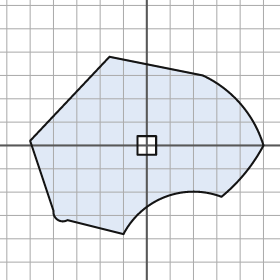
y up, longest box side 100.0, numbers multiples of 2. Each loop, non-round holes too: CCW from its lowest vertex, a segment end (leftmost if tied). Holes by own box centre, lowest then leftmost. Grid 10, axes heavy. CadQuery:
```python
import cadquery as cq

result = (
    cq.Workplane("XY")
    .moveTo(-10.0, -38.0)
    .threePointArc((8.0, -22.0), (32.0, -22.0))
    .threePointArc((42.0, -12.0), (50.0, 0.0))
    .threePointArc((40.0, 18.0), (24.0, 30.0))
    .lineTo(-16.0, 38.0)
    .lineTo(-50.0, 2.0)
    .lineTo(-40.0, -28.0)
    .threePointArc((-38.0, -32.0), (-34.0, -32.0))
    .close()
    .moveTo(-4.0, -4.0)
    .lineTo(4.0, -4.0)
    .lineTo(4.0, 4.0)
    .lineTo(-4.0, 4.0)
    .close()
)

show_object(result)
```